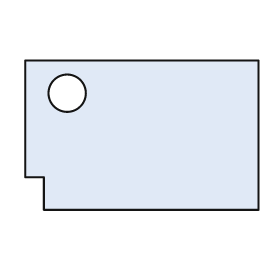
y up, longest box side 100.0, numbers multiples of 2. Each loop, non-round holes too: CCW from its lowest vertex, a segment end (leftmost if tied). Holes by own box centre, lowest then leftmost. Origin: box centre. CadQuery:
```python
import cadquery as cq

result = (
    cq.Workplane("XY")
    .moveTo(-42.0, -32.0)
    .lineTo(50.0, -32.0)
    .lineTo(50.0, 32.0)
    .lineTo(-50.0, 32.0)
    .lineTo(-50.0, -18.0)
    .lineTo(-42.0, -18.0)
    .close()
    .moveTo(-32.0, 18.0)
    .circle(8.0)
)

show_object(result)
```